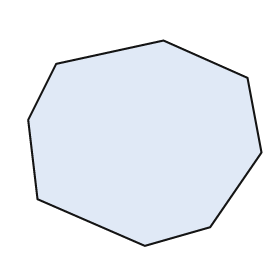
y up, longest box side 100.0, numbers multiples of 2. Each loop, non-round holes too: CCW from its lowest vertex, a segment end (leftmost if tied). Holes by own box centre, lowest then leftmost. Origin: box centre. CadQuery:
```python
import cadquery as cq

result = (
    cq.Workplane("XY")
    .moveTo(0.0, -44.0)
    .lineTo(28.0, -36.0)
    .lineTo(50.0, -4.0)
    .lineTo(44.0, 28.0)
    .lineTo(8.0, 44.0)
    .lineTo(-38.0, 34.0)
    .lineTo(-50.0, 10.0)
    .lineTo(-46.0, -24.0)
    .close()
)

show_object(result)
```